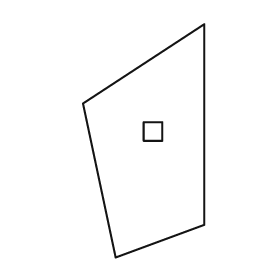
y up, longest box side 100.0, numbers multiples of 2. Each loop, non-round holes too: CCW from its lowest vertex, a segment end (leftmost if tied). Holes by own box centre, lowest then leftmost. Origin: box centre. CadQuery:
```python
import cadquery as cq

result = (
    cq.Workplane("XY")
    .moveTo(-12.0, -50.0)
    .lineTo(26.0, -36.0)
    .lineTo(26.0, 50.0)
    .lineTo(-26.0, 16.0)
    .close()
    .moveTo(0.0, 0.0)
    .lineTo(8.0, 0.0)
    .lineTo(8.0, 8.0)
    .lineTo(0.0, 8.0)
    .close()
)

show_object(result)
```